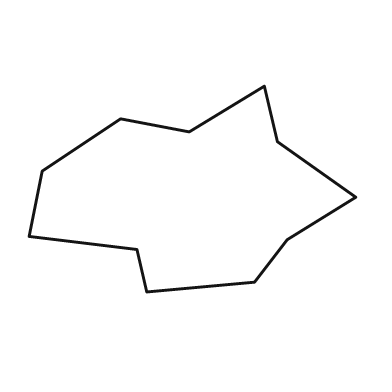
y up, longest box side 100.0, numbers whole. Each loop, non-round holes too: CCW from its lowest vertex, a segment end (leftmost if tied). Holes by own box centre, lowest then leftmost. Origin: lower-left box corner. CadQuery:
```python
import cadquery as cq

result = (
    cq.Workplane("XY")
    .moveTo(36.0, 0.0)
    .lineTo(69.0, 3.0)
    .lineTo(79.0, 16.0)
    .lineTo(100.0, 29.0)
    .lineTo(76.0, 46.0)
    .lineTo(72.0, 63.0)
    .lineTo(49.0, 49.0)
    .lineTo(28.0, 53.0)
    .lineTo(4.0, 37.0)
    .lineTo(0.0, 17.0)
    .lineTo(33.0, 13.0)
    .close()
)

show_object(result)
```